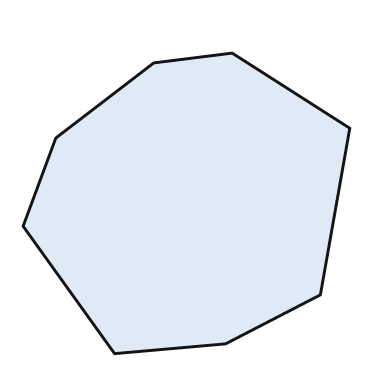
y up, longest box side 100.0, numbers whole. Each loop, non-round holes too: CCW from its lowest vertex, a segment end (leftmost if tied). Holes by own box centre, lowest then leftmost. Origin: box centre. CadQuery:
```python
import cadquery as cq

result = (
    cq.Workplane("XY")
    .moveTo(-22.0, -46.0)
    .lineTo(12.0, -43.0)
    .lineTo(41.0, -28.0)
    .lineTo(50.0, 23.0)
    .lineTo(14.0, 46.0)
    .lineTo(-10.0, 43.0)
    .lineTo(-40.0, 20.0)
    .lineTo(-50.0, -7.0)
    .close()
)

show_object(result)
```